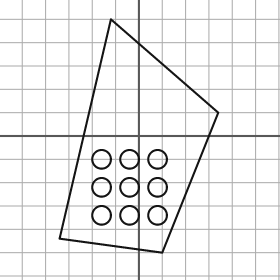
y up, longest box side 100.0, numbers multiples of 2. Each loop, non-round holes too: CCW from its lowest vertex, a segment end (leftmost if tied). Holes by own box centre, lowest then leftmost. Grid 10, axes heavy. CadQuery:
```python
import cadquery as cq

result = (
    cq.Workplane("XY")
    .moveTo(10.0, -50.0)
    .lineTo(34.0, 10.0)
    .lineTo(-12.0, 50.0)
    .lineTo(-34.0, -44.0)
    .close()
    .moveTo(-16.0, -34.0)
    .circle(4.0)
    .moveTo(-4.0, -34.0)
    .circle(4.0)
    .moveTo(8.0, -34.0)
    .circle(4.0)
    .moveTo(-16.0, -22.0)
    .circle(4.0)
    .moveTo(-4.0, -22.0)
    .circle(4.0)
    .moveTo(8.0, -22.0)
    .circle(4.0)
    .moveTo(-16.0, -10.0)
    .circle(4.0)
    .moveTo(-4.0, -10.0)
    .circle(4.0)
    .moveTo(8.0, -10.0)
    .circle(4.0)
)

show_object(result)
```